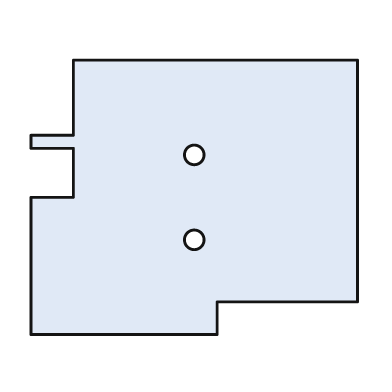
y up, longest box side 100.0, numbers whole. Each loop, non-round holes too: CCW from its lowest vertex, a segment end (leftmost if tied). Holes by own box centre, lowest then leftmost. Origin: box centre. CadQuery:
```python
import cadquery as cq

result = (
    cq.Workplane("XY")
    .moveTo(-50.0, -42.0)
    .lineTo(7.0, -42.0)
    .lineTo(7.0, -32.0)
    .lineTo(50.0, -32.0)
    .lineTo(50.0, 42.0)
    .lineTo(-37.0, 42.0)
    .lineTo(-37.0, 19.0)
    .lineTo(-50.0, 19.0)
    .lineTo(-50.0, 15.0)
    .lineTo(-37.0, 15.0)
    .lineTo(-37.0, 0.0)
    .lineTo(-50.0, 0.0)
    .close()
    .moveTo(0.0, -13.0)
    .circle(3.0)
    .moveTo(0.0, 13.0)
    .circle(3.0)
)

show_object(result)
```